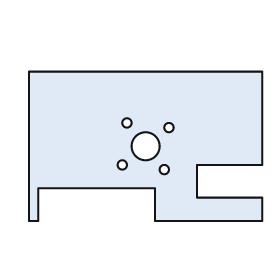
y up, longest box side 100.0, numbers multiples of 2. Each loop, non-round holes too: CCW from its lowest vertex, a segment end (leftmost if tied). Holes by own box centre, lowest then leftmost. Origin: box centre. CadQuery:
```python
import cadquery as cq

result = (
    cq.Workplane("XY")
    .moveTo(-50.0, -32.0)
    .lineTo(-46.0, -32.0)
    .lineTo(-46.0, -18.0)
    .lineTo(4.0, -18.0)
    .lineTo(4.0, -32.0)
    .lineTo(50.0, -32.0)
    .lineTo(50.0, -22.0)
    .lineTo(22.0, -22.0)
    .lineTo(22.0, -8.0)
    .lineTo(50.0, -8.0)
    .lineTo(50.0, 32.0)
    .lineTo(-50.0, 32.0)
    .close()
    .moveTo(8.0, -10.0)
    .circle(2.0)
    .moveTo(-10.0, -8.0)
    .circle(2.0)
    .moveTo(0.0, 0.0)
    .circle(6.0)
    .moveTo(10.0, 8.0)
    .circle(2.0)
    .moveTo(-8.0, 10.0)
    .circle(2.0)
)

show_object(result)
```